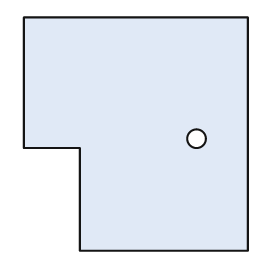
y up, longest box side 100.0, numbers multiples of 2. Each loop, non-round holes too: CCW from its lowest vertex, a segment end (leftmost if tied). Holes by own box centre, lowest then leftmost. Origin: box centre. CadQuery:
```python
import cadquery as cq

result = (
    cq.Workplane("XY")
    .moveTo(-24.0, -50.0)
    .lineTo(48.0, -50.0)
    .lineTo(48.0, 50.0)
    .lineTo(-48.0, 50.0)
    .lineTo(-48.0, -6.0)
    .lineTo(-24.0, -6.0)
    .close()
    .moveTo(26.0, -2.0)
    .circle(4.0)
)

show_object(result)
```